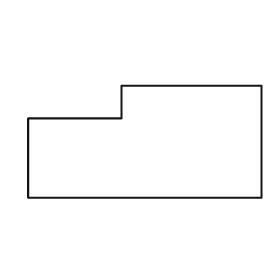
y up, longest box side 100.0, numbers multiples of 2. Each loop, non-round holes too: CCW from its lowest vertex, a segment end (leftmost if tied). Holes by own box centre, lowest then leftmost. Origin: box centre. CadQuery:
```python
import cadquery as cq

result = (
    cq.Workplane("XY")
    .moveTo(-50.0, -24.0)
    .lineTo(50.0, -24.0)
    .lineTo(50.0, 24.0)
    .lineTo(-10.0, 24.0)
    .lineTo(-10.0, 10.0)
    .lineTo(-50.0, 10.0)
    .close()
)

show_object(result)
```